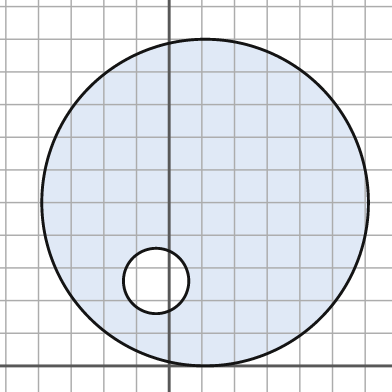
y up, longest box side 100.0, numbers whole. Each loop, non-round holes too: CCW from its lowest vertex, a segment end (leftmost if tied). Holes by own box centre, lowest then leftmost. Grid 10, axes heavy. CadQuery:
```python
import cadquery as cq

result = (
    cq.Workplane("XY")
    .moveTo(11.0, 50.0)
    .circle(50.0)
    .moveTo(-4.0, 26.0)
    .circle(10.0)
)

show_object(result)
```